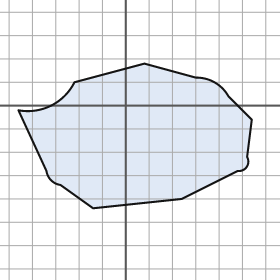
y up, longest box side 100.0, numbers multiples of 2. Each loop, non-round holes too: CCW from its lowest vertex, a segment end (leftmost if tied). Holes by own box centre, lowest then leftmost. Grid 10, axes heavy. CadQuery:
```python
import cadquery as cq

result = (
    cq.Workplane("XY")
    .moveTo(-14.0, -44.0)
    .lineTo(24.0, -40.0)
    .lineTo(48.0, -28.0)
    .threePointArc((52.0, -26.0), (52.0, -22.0))
    .lineTo(54.0, -6.0)
    .lineTo(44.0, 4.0)
    .threePointArc((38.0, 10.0), (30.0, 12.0))
    .lineTo(8.0, 18.0)
    .lineTo(-22.0, 10.0)
    .threePointArc((-32.0, 0.0), (-46.0, -2.0))
    .lineTo(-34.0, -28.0)
    .threePointArc((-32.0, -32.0), (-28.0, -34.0))
    .close()
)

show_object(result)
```